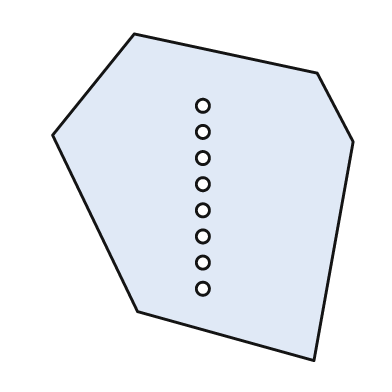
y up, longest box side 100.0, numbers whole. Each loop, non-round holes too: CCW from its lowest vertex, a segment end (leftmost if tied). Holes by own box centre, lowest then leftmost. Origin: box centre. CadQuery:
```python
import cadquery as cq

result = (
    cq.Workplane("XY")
    .moveTo(34.0, -50.0)
    .lineTo(46.0, 17.0)
    .lineTo(35.0, 38.0)
    .lineTo(-21.0, 50.0)
    .lineTo(-46.0, 19.0)
    .lineTo(-20.0, -35.0)
    .close()
    .moveTo(0.0, -28.0)
    .circle(2.0)
    .moveTo(0.0, -20.0)
    .circle(2.0)
    .moveTo(0.0, -12.0)
    .circle(2.0)
    .moveTo(0.0, -4.0)
    .circle(2.0)
    .moveTo(0.0, 4.0)
    .circle(2.0)
    .moveTo(0.0, 12.0)
    .circle(2.0)
    .moveTo(0.0, 20.0)
    .circle(2.0)
    .moveTo(0.0, 28.0)
    .circle(2.0)
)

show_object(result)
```